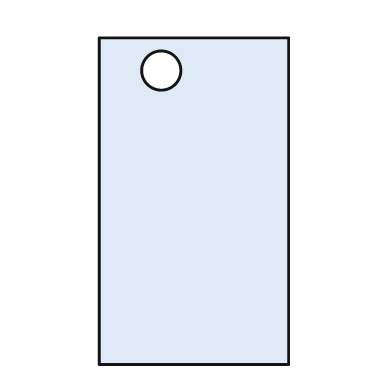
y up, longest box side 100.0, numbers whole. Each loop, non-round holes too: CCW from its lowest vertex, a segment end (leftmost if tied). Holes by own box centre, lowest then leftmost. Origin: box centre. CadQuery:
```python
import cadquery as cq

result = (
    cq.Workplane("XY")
    .moveTo(-29.0, -50.0)
    .lineTo(29.0, -50.0)
    .lineTo(29.0, 50.0)
    .lineTo(-29.0, 50.0)
    .close()
    .moveTo(-10.0, 40.0)
    .circle(6.0)
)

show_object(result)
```